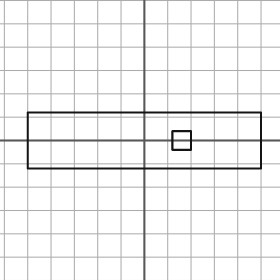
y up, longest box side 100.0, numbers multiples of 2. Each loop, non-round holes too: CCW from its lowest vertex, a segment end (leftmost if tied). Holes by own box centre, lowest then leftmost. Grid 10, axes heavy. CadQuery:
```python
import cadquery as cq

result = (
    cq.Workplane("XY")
    .moveTo(-50.0, -12.0)
    .lineTo(50.0, -12.0)
    .lineTo(50.0, 12.0)
    .lineTo(-50.0, 12.0)
    .close()
    .moveTo(12.0, -4.0)
    .lineTo(20.0, -4.0)
    .lineTo(20.0, 4.0)
    .lineTo(12.0, 4.0)
    .close()
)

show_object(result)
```